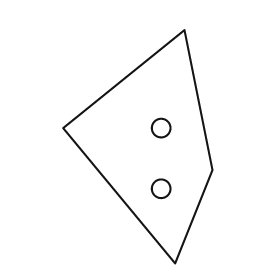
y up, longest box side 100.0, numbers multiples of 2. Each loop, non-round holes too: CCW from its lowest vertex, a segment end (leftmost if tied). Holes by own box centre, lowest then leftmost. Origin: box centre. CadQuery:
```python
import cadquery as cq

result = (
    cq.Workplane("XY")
    .moveTo(16.0, -50.0)
    .lineTo(32.0, -10.0)
    .lineTo(20.0, 50.0)
    .lineTo(-32.0, 8.0)
    .close()
    .moveTo(10.0, -18.0)
    .circle(4.0)
    .moveTo(10.0, 8.0)
    .circle(4.0)
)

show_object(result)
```